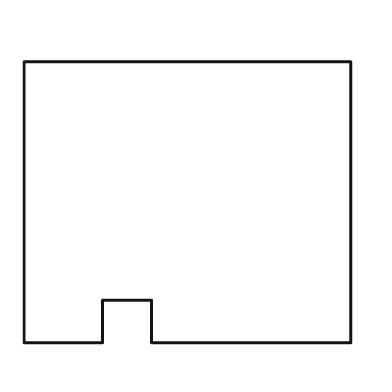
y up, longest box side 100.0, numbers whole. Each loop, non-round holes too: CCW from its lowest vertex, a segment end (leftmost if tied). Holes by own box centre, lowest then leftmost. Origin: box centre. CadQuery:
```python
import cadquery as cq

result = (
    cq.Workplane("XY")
    .moveTo(-50.0, -43.0)
    .lineTo(-26.0, -43.0)
    .lineTo(-26.0, -30.0)
    .lineTo(-11.0, -30.0)
    .lineTo(-11.0, -43.0)
    .lineTo(50.0, -43.0)
    .lineTo(50.0, 43.0)
    .lineTo(-50.0, 43.0)
    .close()
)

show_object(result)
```